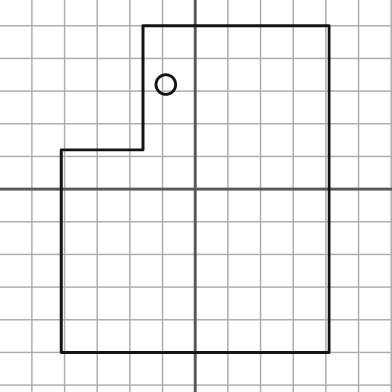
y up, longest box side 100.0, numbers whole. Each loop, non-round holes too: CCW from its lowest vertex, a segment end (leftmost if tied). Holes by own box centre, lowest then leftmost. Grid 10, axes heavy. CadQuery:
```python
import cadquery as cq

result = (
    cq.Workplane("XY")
    .moveTo(-41.0, -50.0)
    .lineTo(41.0, -50.0)
    .lineTo(41.0, 50.0)
    .lineTo(-16.0, 50.0)
    .lineTo(-16.0, 12.0)
    .lineTo(-41.0, 12.0)
    .close()
    .moveTo(-9.0, 32.0)
    .circle(3.0)
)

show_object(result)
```